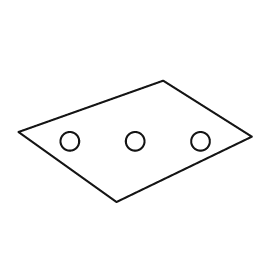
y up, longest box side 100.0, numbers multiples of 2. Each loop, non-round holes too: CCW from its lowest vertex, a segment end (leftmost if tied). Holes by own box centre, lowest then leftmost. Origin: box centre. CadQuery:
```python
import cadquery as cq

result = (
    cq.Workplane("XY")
    .moveTo(-8.0, -26.0)
    .lineTo(50.0, 2.0)
    .lineTo(12.0, 26.0)
    .lineTo(-50.0, 4.0)
    .close()
    .moveTo(-28.0, 0.0)
    .circle(4.0)
    .moveTo(0.0, 0.0)
    .circle(4.0)
    .moveTo(28.0, 0.0)
    .circle(4.0)
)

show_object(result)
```